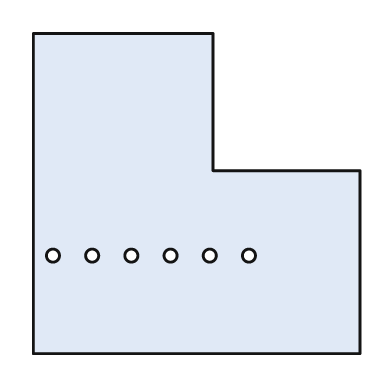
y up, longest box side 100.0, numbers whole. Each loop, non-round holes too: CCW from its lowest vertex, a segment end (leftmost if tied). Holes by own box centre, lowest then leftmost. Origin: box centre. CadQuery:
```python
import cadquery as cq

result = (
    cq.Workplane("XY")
    .moveTo(-50.0, -49.0)
    .lineTo(50.0, -49.0)
    .lineTo(50.0, 7.0)
    .lineTo(5.0, 7.0)
    .lineTo(5.0, 49.0)
    .lineTo(-50.0, 49.0)
    .close()
    .moveTo(-44.0, -19.0)
    .circle(2.0)
    .moveTo(-32.0, -19.0)
    .circle(2.0)
    .moveTo(-20.0, -19.0)
    .circle(2.0)
    .moveTo(-8.0, -19.0)
    .circle(2.0)
    .moveTo(4.0, -19.0)
    .circle(2.0)
    .moveTo(16.0, -19.0)
    .circle(2.0)
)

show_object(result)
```